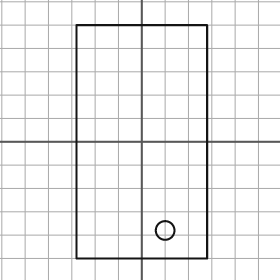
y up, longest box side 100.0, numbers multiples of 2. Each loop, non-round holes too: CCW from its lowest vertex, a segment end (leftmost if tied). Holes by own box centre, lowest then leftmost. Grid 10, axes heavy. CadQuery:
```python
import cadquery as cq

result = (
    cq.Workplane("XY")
    .moveTo(-28.0, -50.0)
    .lineTo(28.0, -50.0)
    .lineTo(28.0, 50.0)
    .lineTo(-28.0, 50.0)
    .close()
    .moveTo(10.0, -38.0)
    .circle(4.0)
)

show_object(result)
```